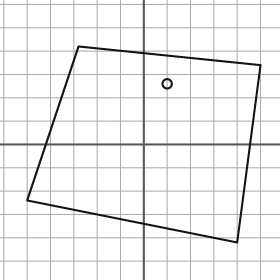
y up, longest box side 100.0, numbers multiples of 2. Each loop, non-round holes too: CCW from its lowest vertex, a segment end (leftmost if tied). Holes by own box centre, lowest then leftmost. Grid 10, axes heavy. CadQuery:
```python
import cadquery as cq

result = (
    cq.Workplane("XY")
    .moveTo(40.0, -42.0)
    .lineTo(50.0, 34.0)
    .lineTo(-28.0, 42.0)
    .lineTo(-50.0, -24.0)
    .close()
    .moveTo(10.0, 26.0)
    .circle(2.0)
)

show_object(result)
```